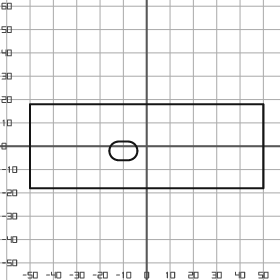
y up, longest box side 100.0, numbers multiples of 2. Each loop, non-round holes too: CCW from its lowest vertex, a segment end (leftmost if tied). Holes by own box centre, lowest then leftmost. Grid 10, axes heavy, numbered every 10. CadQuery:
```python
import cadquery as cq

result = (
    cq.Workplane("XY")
    .moveTo(-50.0, -18.0)
    .lineTo(50.0, -18.0)
    .lineTo(50.0, 18.0)
    .lineTo(-50.0, 18.0)
    .close()
    .moveTo(-12.0, -6.0)
    .lineTo(-8.0, -6.0)
    .threePointArc((-4.0, -2.0), (-8.0, 2.0))
    .lineTo(-12.0, 2.0)
    .threePointArc((-16.0, -2.0), (-12.0, -6.0))
    .close()
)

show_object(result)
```